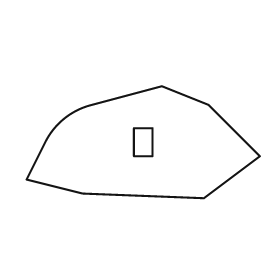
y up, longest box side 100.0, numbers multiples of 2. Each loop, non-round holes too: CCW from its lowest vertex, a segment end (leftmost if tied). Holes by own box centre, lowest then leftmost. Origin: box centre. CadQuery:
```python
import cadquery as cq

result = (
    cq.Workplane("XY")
    .moveTo(26.0, -24.0)
    .lineTo(50.0, -6.0)
    .lineTo(28.0, 16.0)
    .lineTo(8.0, 24.0)
    .lineTo(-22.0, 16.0)
    .threePointArc((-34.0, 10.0), (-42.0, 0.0))
    .lineTo(-50.0, -16.0)
    .lineTo(-26.0, -22.0)
    .close()
    .moveTo(-4.0, -6.0)
    .lineTo(4.0, -6.0)
    .lineTo(4.0, 6.0)
    .lineTo(-4.0, 6.0)
    .close()
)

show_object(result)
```